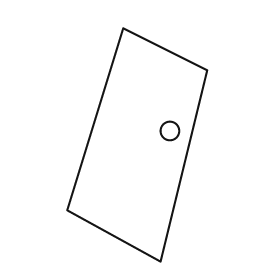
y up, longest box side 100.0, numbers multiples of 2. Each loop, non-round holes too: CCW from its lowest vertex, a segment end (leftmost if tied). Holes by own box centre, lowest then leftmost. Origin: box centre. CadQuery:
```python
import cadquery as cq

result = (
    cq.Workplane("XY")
    .moveTo(10.0, -50.0)
    .lineTo(30.0, 32.0)
    .lineTo(-6.0, 50.0)
    .lineTo(-30.0, -28.0)
    .close()
    .moveTo(14.0, 6.0)
    .circle(4.0)
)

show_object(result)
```